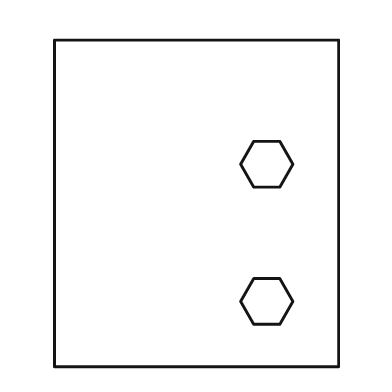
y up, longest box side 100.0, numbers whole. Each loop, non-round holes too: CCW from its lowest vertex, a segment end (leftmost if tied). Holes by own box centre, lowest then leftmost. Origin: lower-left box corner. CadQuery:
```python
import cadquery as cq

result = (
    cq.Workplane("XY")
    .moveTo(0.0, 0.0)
    .lineTo(87.0, 0.0)
    .lineTo(87.0, 100.0)
    .lineTo(0.0, 100.0)
    .close()
    .moveTo(61.0, 13.0)
    .lineTo(69.0, 13.0)
    .lineTo(73.0, 20.0)
    .lineTo(69.0, 27.0)
    .lineTo(61.0, 27.0)
    .lineTo(57.0, 20.0)
    .close()
    .moveTo(61.0, 55.0)
    .lineTo(69.0, 55.0)
    .lineTo(73.0, 62.0)
    .lineTo(69.0, 69.0)
    .lineTo(61.0, 69.0)
    .lineTo(57.0, 62.0)
    .close()
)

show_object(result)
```